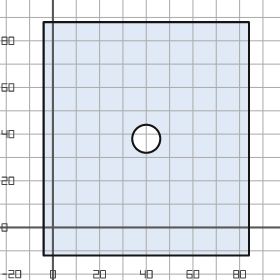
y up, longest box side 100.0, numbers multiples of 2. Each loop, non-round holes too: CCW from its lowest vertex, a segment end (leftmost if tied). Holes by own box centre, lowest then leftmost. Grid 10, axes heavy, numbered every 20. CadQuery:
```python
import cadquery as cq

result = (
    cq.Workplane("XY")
    .moveTo(-4.0, -12.0)
    .lineTo(84.0, -12.0)
    .lineTo(84.0, 88.0)
    .lineTo(-4.0, 88.0)
    .close()
    .moveTo(40.0, 38.0)
    .circle(6.0)
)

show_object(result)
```